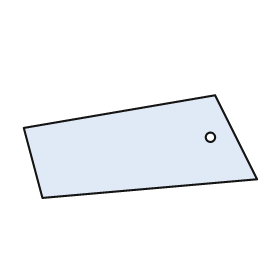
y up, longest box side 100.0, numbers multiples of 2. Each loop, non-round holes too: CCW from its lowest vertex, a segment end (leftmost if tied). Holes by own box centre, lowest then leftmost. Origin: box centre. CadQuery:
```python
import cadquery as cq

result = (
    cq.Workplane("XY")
    .moveTo(-42.0, -22.0)
    .lineTo(50.0, -14.0)
    .lineTo(32.0, 22.0)
    .lineTo(-50.0, 8.0)
    .close()
    .moveTo(30.0, 4.0)
    .circle(2.0)
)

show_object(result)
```